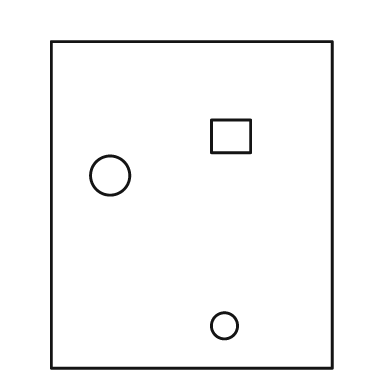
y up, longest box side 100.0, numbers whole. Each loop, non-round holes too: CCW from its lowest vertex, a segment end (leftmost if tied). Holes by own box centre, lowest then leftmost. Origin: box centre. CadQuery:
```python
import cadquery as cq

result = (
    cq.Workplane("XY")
    .moveTo(-43.0, -50.0)
    .lineTo(43.0, -50.0)
    .lineTo(43.0, 50.0)
    .lineTo(-43.0, 50.0)
    .close()
    .moveTo(10.0, -37.0)
    .circle(4.0)
    .moveTo(-25.0, 9.0)
    .circle(6.0)
    .moveTo(6.0, 16.0)
    .lineTo(18.0, 16.0)
    .lineTo(18.0, 26.0)
    .lineTo(6.0, 26.0)
    .close()
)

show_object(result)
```